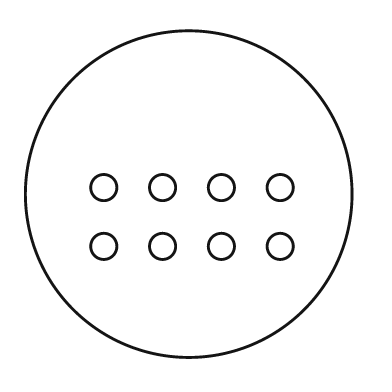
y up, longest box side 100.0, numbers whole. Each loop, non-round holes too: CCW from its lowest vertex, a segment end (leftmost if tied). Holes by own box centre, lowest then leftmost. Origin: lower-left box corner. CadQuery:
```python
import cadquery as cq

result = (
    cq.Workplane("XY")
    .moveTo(50.0, 50.0)
    .circle(50.0)
    .moveTo(24.0, 34.0)
    .circle(4.0)
    .moveTo(42.0, 34.0)
    .circle(4.0)
    .moveTo(60.0, 34.0)
    .circle(4.0)
    .moveTo(78.0, 34.0)
    .circle(4.0)
    .moveTo(24.0, 52.0)
    .circle(4.0)
    .moveTo(42.0, 52.0)
    .circle(4.0)
    .moveTo(60.0, 52.0)
    .circle(4.0)
    .moveTo(78.0, 52.0)
    .circle(4.0)
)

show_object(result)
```